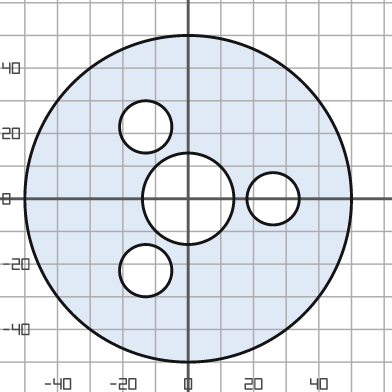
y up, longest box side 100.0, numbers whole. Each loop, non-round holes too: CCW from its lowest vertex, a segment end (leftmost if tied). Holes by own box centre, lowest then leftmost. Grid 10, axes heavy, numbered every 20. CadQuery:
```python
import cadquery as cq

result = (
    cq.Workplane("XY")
    .moveTo(0.0, 0.0)
    .circle(50.0)
    .moveTo(-13.0, -22.0)
    .circle(8.0)
    .moveTo(0.0, 0.0)
    .circle(14.0)
    .moveTo(26.0, 0.0)
    .circle(8.0)
    .moveTo(-13.0, 22.0)
    .circle(8.0)
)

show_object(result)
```